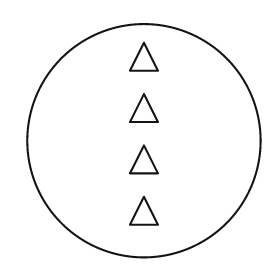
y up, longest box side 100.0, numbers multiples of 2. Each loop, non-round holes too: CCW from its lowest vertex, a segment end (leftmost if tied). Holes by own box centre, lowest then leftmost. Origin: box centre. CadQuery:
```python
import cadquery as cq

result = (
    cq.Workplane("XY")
    .moveTo(0.0, 0.0)
    .circle(50.0)
    .moveTo(-6.0, -36.0)
    .lineTo(6.0, -36.0)
    .lineTo(0.0, -24.0)
    .close()
    .moveTo(-6.0, -14.0)
    .lineTo(6.0, -14.0)
    .lineTo(0.0, -2.0)
    .close()
    .moveTo(-6.0, 8.0)
    .lineTo(6.0, 8.0)
    .lineTo(0.0, 20.0)
    .close()
    .moveTo(-6.0, 30.0)
    .lineTo(6.0, 30.0)
    .lineTo(0.0, 42.0)
    .close()
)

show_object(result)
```